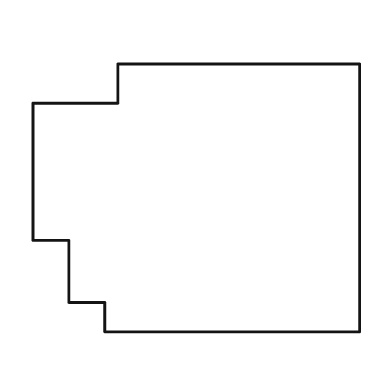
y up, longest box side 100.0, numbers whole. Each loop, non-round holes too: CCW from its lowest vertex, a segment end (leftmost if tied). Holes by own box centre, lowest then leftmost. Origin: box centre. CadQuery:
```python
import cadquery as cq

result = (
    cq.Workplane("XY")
    .moveTo(-28.0, -41.0)
    .lineTo(50.0, -41.0)
    .lineTo(50.0, 41.0)
    .lineTo(-24.0, 41.0)
    .lineTo(-24.0, 29.0)
    .lineTo(-50.0, 29.0)
    .lineTo(-50.0, -13.0)
    .lineTo(-39.0, -13.0)
    .lineTo(-39.0, -32.0)
    .lineTo(-28.0, -32.0)
    .close()
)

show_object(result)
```